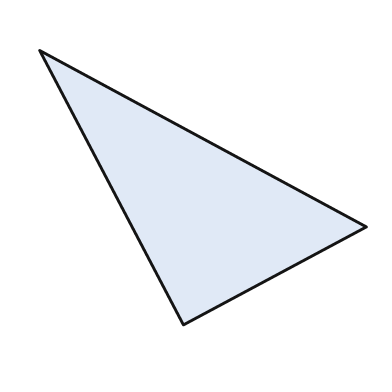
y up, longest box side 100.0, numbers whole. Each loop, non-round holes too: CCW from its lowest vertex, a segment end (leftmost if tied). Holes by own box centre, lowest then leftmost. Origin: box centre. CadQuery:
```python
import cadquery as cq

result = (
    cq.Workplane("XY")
    .moveTo(-6.0, -42.0)
    .lineTo(50.0, -12.0)
    .lineTo(-50.0, 42.0)
    .close()
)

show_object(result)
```